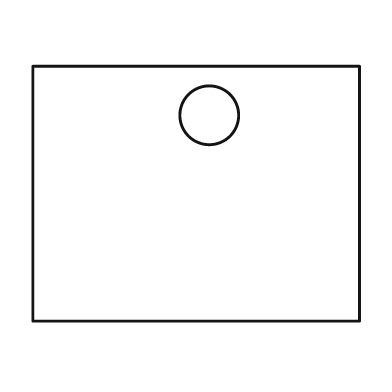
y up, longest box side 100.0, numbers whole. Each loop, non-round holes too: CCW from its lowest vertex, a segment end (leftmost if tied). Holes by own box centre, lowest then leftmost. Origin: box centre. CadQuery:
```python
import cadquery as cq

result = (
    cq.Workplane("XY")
    .moveTo(-50.0, -39.0)
    .lineTo(50.0, -39.0)
    .lineTo(50.0, 39.0)
    .lineTo(-50.0, 39.0)
    .close()
    .moveTo(4.0, 24.0)
    .circle(9.0)
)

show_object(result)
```